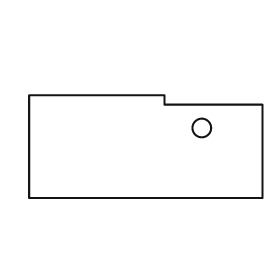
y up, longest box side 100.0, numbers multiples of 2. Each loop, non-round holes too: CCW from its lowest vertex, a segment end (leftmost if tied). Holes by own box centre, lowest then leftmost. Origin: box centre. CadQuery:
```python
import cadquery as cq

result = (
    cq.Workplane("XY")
    .moveTo(-50.0, -22.0)
    .lineTo(50.0, -22.0)
    .lineTo(50.0, 18.0)
    .lineTo(8.0, 18.0)
    .lineTo(8.0, 22.0)
    .lineTo(-50.0, 22.0)
    .close()
    .moveTo(24.0, 8.0)
    .circle(4.0)
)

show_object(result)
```